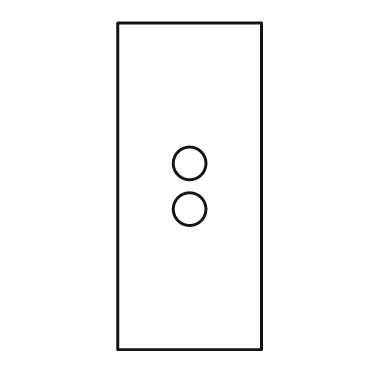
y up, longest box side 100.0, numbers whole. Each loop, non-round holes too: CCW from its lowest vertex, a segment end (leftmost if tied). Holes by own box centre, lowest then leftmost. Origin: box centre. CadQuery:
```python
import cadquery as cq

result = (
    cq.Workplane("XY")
    .moveTo(-22.0, -50.0)
    .lineTo(22.0, -50.0)
    .lineTo(22.0, 50.0)
    .lineTo(-22.0, 50.0)
    .close()
    .moveTo(0.0, -7.0)
    .circle(5.0)
    .moveTo(0.0, 7.0)
    .circle(5.0)
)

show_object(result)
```